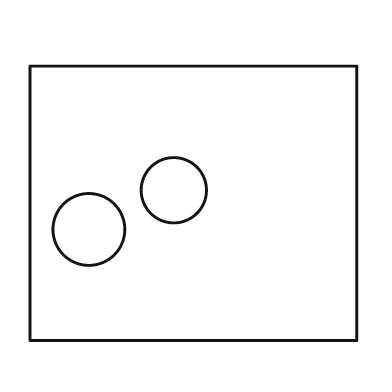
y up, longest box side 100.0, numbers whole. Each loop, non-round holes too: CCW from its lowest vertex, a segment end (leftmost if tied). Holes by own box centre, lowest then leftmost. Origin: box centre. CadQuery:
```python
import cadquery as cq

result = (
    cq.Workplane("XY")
    .moveTo(-50.0, -42.0)
    .lineTo(50.0, -42.0)
    .lineTo(50.0, 42.0)
    .lineTo(-50.0, 42.0)
    .close()
    .moveTo(-32.0, -8.0)
    .circle(11.0)
    .moveTo(-6.0, 4.0)
    .circle(10.0)
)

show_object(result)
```